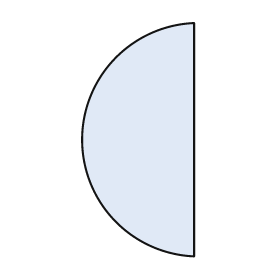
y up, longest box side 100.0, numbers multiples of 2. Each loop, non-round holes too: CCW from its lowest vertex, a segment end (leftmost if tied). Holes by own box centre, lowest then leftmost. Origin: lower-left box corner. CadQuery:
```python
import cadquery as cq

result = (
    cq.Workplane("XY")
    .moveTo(48.0, 0.0)
    .lineTo(48.0, 100.0)
    .threePointArc((0.0, 50.0), (48.0, 0.0))
    .close()
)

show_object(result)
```